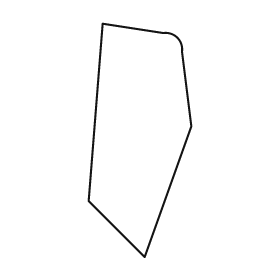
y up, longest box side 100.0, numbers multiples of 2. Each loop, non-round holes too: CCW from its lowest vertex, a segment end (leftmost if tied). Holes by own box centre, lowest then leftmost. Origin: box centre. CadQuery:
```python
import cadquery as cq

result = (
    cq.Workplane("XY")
    .moveTo(2.0, -50.0)
    .lineTo(22.0, 6.0)
    .lineTo(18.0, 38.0)
    .threePointArc((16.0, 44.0), (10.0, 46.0))
    .lineTo(-16.0, 50.0)
    .lineTo(-22.0, -26.0)
    .close()
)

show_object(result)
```